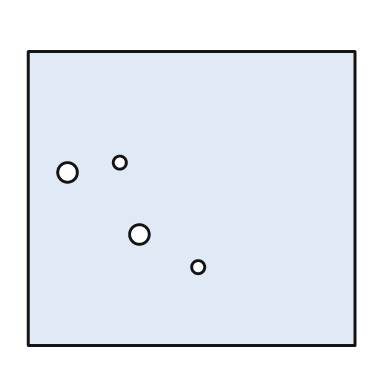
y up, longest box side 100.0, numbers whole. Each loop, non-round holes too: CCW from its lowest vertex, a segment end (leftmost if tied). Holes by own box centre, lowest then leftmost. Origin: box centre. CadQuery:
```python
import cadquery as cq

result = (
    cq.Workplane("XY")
    .moveTo(-50.0, -45.0)
    .lineTo(50.0, -45.0)
    .lineTo(50.0, 45.0)
    .lineTo(-50.0, 45.0)
    .close()
    .moveTo(2.0, -21.0)
    .circle(2.0)
    .moveTo(-16.0, -11.0)
    .circle(3.0)
    .moveTo(-38.0, 8.0)
    .circle(3.0)
    .moveTo(-22.0, 11.0)
    .circle(2.0)
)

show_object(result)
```